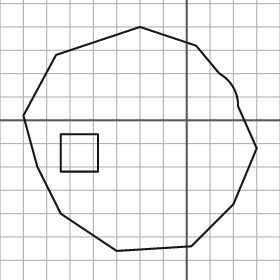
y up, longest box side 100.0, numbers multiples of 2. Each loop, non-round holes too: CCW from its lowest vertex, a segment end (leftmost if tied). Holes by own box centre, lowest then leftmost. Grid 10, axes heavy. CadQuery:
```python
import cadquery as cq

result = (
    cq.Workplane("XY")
    .moveTo(-30.0, -56.0)
    .lineTo(2.0, -54.0)
    .lineTo(20.0, -36.0)
    .lineTo(30.0, -12.0)
    .lineTo(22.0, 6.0)
    .threePointArc((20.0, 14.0), (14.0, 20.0))
    .lineTo(4.0, 32.0)
    .lineTo(-20.0, 40.0)
    .lineTo(-56.0, 28.0)
    .lineTo(-70.0, 2.0)
    .lineTo(-64.0, -20.0)
    .lineTo(-54.0, -40.0)
    .close()
    .moveTo(-54.0, -22.0)
    .lineTo(-38.0, -22.0)
    .lineTo(-38.0, -6.0)
    .lineTo(-54.0, -6.0)
    .close()
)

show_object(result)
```